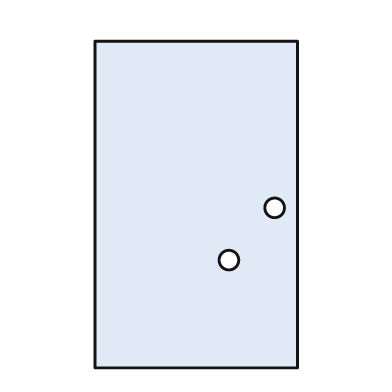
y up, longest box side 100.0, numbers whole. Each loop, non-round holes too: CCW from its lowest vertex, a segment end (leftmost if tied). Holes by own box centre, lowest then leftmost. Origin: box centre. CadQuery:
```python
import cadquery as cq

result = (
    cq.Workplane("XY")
    .moveTo(-31.0, -50.0)
    .lineTo(31.0, -50.0)
    .lineTo(31.0, 50.0)
    .lineTo(-31.0, 50.0)
    .close()
    .moveTo(10.0, -17.0)
    .circle(3.0)
    .moveTo(24.0, -1.0)
    .circle(3.0)
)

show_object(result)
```